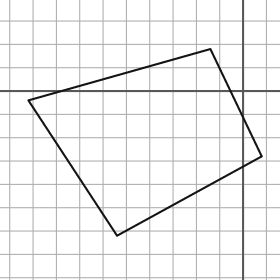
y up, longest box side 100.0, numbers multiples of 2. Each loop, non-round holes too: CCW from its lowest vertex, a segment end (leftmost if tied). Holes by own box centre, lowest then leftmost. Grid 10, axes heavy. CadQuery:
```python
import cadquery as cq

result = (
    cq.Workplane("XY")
    .moveTo(-54.0, -62.0)
    .lineTo(8.0, -28.0)
    .lineTo(-14.0, 18.0)
    .lineTo(-92.0, -4.0)
    .close()
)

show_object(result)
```